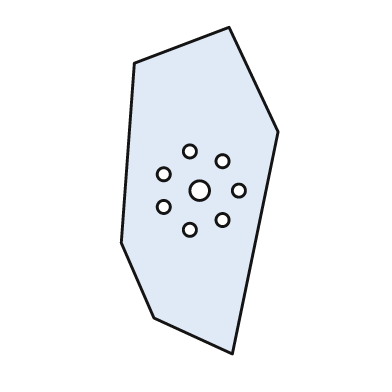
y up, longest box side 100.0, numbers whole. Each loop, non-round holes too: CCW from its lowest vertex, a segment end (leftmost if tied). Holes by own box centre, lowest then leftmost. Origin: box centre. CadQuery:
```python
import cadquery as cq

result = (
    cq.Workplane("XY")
    .moveTo(10.0, -50.0)
    .lineTo(24.0, 18.0)
    .lineTo(9.0, 50.0)
    .lineTo(-20.0, 39.0)
    .lineTo(-24.0, -16.0)
    .lineTo(-14.0, -39.0)
    .close()
    .moveTo(-3.0, -12.0)
    .circle(2.0)
    .moveTo(7.0, -9.0)
    .circle(2.0)
    .moveTo(-11.0, -5.0)
    .circle(2.0)
    .moveTo(0.0, 0.0)
    .circle(3.0)
    .moveTo(12.0, 0.0)
    .circle(2.0)
    .moveTo(-11.0, 5.0)
    .circle(2.0)
    .moveTo(7.0, 9.0)
    .circle(2.0)
    .moveTo(-3.0, 12.0)
    .circle(2.0)
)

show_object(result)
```